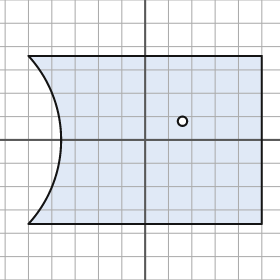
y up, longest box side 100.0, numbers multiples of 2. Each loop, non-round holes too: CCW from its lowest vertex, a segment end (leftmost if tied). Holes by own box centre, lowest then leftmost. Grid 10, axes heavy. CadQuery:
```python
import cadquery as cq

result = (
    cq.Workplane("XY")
    .moveTo(-50.0, -36.0)
    .lineTo(50.0, -36.0)
    .lineTo(50.0, 36.0)
    .lineTo(-50.0, 36.0)
    .threePointArc((-36.0, 0.0), (-50.0, -36.0))
    .close()
    .moveTo(16.0, 8.0)
    .circle(2.0)
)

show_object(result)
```